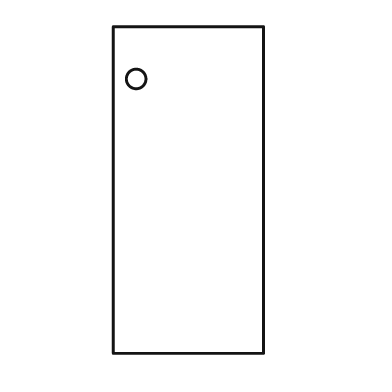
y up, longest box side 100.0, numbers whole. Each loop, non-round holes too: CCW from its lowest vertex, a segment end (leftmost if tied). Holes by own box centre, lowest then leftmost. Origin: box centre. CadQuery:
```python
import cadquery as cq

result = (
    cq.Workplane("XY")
    .moveTo(-23.0, -50.0)
    .lineTo(23.0, -50.0)
    .lineTo(23.0, 50.0)
    .lineTo(-23.0, 50.0)
    .close()
    .moveTo(-16.0, 34.0)
    .circle(3.0)
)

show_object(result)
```